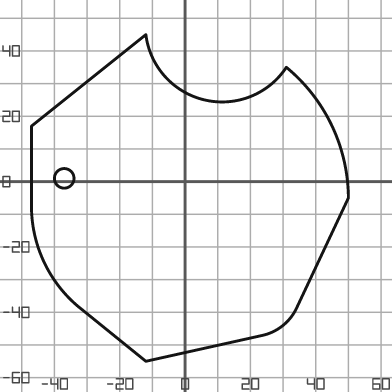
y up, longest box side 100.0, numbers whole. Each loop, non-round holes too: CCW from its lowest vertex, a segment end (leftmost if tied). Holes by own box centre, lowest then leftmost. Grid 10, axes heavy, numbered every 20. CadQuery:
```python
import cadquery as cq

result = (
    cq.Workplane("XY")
    .moveTo(-12.0, -55.0)
    .lineTo(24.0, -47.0)
    .threePointArc((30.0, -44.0), (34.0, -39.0))
    .lineTo(50.0, -5.0)
    .threePointArc((45.0, 17.0), (31.0, 35.0))
    .threePointArc((6.0, 25.0), (-12.0, 45.0))
    .lineTo(-47.0, 17.0)
    .lineTo(-47.0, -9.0)
    .threePointArc((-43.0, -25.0), (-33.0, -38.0))
    .close()
    .moveTo(-37.0, 1.0)
    .circle(3.0)
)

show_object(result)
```